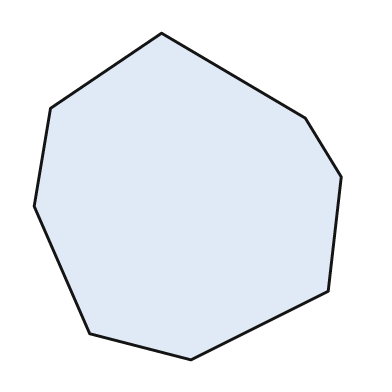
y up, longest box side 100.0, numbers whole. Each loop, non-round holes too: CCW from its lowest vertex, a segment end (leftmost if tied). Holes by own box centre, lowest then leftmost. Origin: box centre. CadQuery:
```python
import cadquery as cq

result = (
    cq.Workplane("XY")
    .moveTo(1.0, -50.0)
    .lineTo(43.0, -29.0)
    .lineTo(47.0, 6.0)
    .lineTo(36.0, 24.0)
    .lineTo(-8.0, 50.0)
    .lineTo(-42.0, 27.0)
    .lineTo(-47.0, -3.0)
    .lineTo(-30.0, -42.0)
    .close()
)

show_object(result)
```